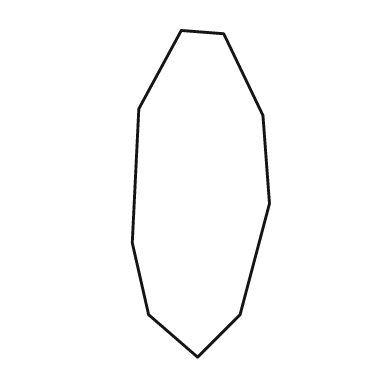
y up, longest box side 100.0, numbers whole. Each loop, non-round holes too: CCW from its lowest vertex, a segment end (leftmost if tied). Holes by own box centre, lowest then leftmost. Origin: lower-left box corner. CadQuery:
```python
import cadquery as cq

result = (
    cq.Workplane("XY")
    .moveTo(20.0, 0.0)
    .lineTo(33.0, 13.0)
    .lineTo(42.0, 47.0)
    .lineTo(40.0, 74.0)
    .lineTo(28.0, 99.0)
    .lineTo(15.0, 100.0)
    .lineTo(2.0, 76.0)
    .lineTo(0.0, 35.0)
    .lineTo(5.0, 13.0)
    .close()
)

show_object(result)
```